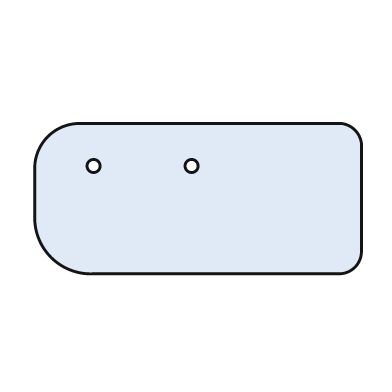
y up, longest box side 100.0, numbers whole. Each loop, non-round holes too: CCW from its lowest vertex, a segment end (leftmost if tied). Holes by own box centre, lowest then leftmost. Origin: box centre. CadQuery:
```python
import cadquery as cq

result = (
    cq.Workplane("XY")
    .moveTo(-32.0, -23.0)
    .lineTo(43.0, -23.0)
    .threePointArc((48.0, -21.0), (50.0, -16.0))
    .lineTo(50.0, 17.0)
    .threePointArc((48.0, 21.0), (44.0, 23.0))
    .lineTo(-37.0, 23.0)
    .threePointArc((-46.0, 19.0), (-50.0, 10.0))
    .lineTo(-50.0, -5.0)
    .threePointArc((-45.0, -18.0), (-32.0, -23.0))
    .close()
    .moveTo(-32.0, 10.0)
    .circle(2.0)
    .moveTo(-2.0, 10.0)
    .circle(2.0)
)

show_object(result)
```